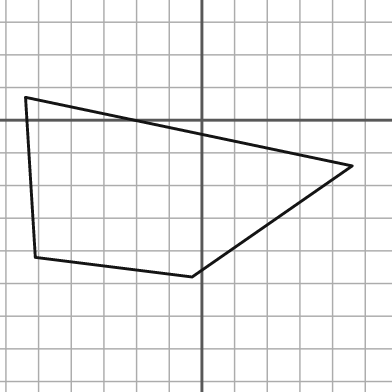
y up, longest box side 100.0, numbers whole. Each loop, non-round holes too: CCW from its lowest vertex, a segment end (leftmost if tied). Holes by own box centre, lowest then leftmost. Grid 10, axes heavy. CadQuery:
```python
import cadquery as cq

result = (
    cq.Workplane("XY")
    .moveTo(-3.0, -48.0)
    .lineTo(46.0, -14.0)
    .lineTo(-54.0, 7.0)
    .lineTo(-51.0, -42.0)
    .close()
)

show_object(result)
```